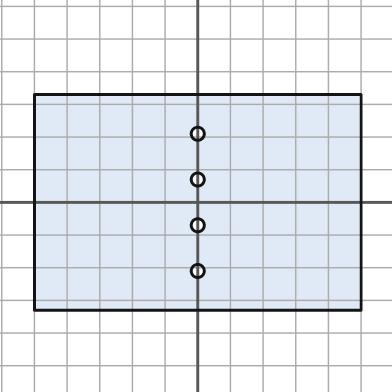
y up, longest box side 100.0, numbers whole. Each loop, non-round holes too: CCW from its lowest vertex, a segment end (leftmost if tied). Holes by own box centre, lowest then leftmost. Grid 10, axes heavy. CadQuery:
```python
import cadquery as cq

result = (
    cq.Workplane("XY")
    .moveTo(-50.0, -33.0)
    .lineTo(50.0, -33.0)
    .lineTo(50.0, 33.0)
    .lineTo(-50.0, 33.0)
    .close()
    .moveTo(0.0, -21.0)
    .circle(2.0)
    .moveTo(0.0, -7.0)
    .circle(2.0)
    .moveTo(0.0, 7.0)
    .circle(2.0)
    .moveTo(0.0, 21.0)
    .circle(2.0)
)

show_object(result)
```